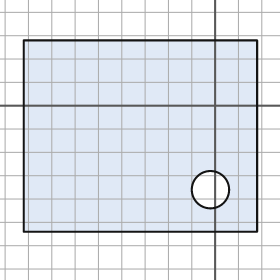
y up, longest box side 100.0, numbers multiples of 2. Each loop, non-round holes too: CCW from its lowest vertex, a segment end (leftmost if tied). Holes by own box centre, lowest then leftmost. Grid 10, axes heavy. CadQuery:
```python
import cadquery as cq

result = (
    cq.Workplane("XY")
    .moveTo(-82.0, -54.0)
    .lineTo(18.0, -54.0)
    .lineTo(18.0, 28.0)
    .lineTo(-82.0, 28.0)
    .close()
    .moveTo(-2.0, -36.0)
    .circle(8.0)
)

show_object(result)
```